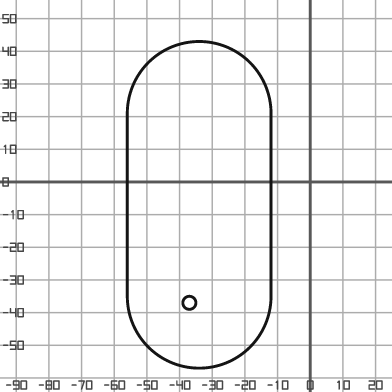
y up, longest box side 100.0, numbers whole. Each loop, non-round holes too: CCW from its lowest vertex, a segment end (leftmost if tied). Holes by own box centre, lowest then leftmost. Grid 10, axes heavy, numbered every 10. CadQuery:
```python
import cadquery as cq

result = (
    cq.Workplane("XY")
    .moveTo(-56.0, -35.0)
    .threePointArc((-34.0, -57.0), (-12.0, -35.0))
    .lineTo(-12.0, 21.0)
    .threePointArc((-34.0, 43.0), (-56.0, 21.0))
    .close()
    .moveTo(-37.0, -37.0)
    .circle(2.0)
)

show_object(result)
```